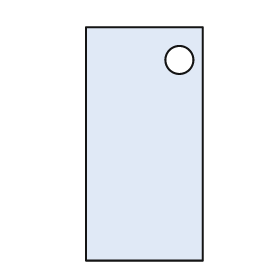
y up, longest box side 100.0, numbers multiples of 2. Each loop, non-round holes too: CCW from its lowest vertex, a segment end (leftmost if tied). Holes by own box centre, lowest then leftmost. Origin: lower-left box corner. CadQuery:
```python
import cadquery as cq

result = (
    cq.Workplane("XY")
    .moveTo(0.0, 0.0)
    .lineTo(50.0, 0.0)
    .lineTo(50.0, 100.0)
    .lineTo(0.0, 100.0)
    .close()
    .moveTo(40.0, 86.0)
    .circle(6.0)
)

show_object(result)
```